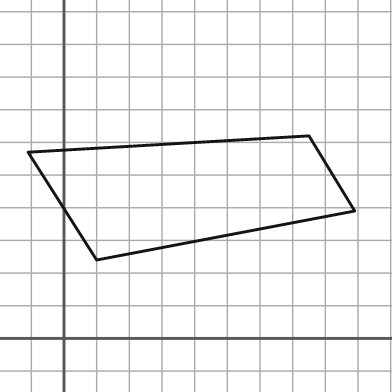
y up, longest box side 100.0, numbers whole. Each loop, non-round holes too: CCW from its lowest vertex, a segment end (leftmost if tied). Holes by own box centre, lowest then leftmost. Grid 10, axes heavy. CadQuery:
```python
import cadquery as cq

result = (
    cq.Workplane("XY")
    .moveTo(10.0, 24.0)
    .lineTo(89.0, 39.0)
    .lineTo(75.0, 62.0)
    .lineTo(-11.0, 57.0)
    .close()
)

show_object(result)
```